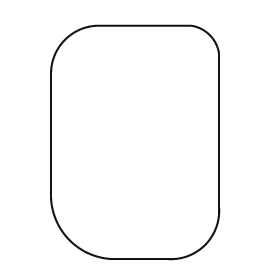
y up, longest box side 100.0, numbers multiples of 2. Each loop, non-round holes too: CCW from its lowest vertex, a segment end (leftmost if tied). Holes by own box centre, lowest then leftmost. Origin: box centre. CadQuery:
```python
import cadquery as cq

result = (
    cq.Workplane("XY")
    .moveTo(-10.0, -50.0)
    .lineTo(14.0, -50.0)
    .threePointArc((30.0, -44.0), (36.0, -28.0))
    .lineTo(36.0, 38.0)
    .threePointArc((32.0, 46.0), (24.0, 50.0))
    .lineTo(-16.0, 50.0)
    .threePointArc((-30.0, 44.0), (-36.0, 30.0))
    .lineTo(-36.0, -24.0)
    .threePointArc((-28.0, -42.0), (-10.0, -50.0))
    .close()
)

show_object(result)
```